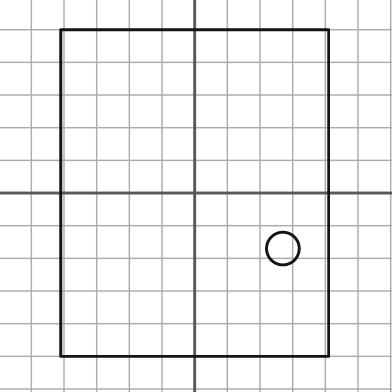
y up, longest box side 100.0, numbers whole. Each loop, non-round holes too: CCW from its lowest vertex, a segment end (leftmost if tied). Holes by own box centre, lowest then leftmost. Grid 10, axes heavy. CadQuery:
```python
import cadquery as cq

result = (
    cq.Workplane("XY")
    .moveTo(-41.0, -50.0)
    .lineTo(41.0, -50.0)
    .lineTo(41.0, 50.0)
    .lineTo(-41.0, 50.0)
    .close()
    .moveTo(27.0, -17.0)
    .circle(5.0)
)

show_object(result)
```